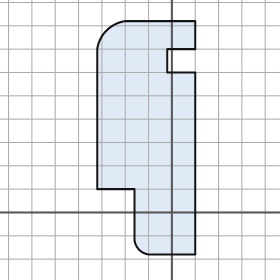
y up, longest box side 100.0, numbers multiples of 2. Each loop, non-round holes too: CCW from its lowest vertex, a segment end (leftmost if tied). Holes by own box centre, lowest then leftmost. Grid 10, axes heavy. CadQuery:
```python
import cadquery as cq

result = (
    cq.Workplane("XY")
    .moveTo(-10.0, -18.0)
    .lineTo(10.0, -18.0)
    .lineTo(10.0, 60.0)
    .lineTo(-2.0, 60.0)
    .lineTo(-2.0, 70.0)
    .lineTo(10.0, 70.0)
    .lineTo(10.0, 82.0)
    .lineTo(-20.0, 82.0)
    .threePointArc((-28.0, 78.0), (-32.0, 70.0))
    .lineTo(-32.0, 10.0)
    .lineTo(-16.0, 10.0)
    .lineTo(-16.0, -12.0)
    .threePointArc((-14.0, -16.0), (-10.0, -18.0))
    .close()
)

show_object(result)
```